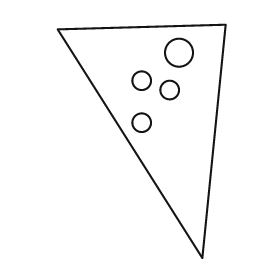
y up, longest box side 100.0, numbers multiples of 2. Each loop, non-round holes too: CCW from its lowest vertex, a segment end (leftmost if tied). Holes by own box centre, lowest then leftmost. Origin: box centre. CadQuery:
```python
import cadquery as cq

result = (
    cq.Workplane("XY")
    .moveTo(26.0, -50.0)
    .lineTo(36.0, 50.0)
    .lineTo(-36.0, 48.0)
    .close()
    .moveTo(0.0, 8.0)
    .circle(4.0)
    .moveTo(12.0, 22.0)
    .circle(4.0)
    .moveTo(0.0, 26.0)
    .circle(4.0)
    .moveTo(16.0, 38.0)
    .circle(6.0)
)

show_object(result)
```